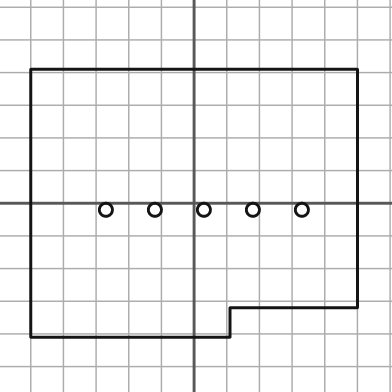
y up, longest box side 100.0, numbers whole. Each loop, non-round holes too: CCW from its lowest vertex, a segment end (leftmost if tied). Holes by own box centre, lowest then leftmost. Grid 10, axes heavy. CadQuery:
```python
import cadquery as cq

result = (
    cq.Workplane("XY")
    .moveTo(-50.0, -41.0)
    .lineTo(11.0, -41.0)
    .lineTo(11.0, -32.0)
    .lineTo(50.0, -32.0)
    .lineTo(50.0, 41.0)
    .lineTo(-50.0, 41.0)
    .close()
    .moveTo(-27.0, -2.0)
    .circle(2.0)
    .moveTo(-12.0, -2.0)
    .circle(2.0)
    .moveTo(3.0, -2.0)
    .circle(2.0)
    .moveTo(18.0, -2.0)
    .circle(2.0)
    .moveTo(33.0, -2.0)
    .circle(2.0)
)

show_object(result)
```